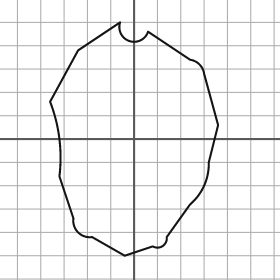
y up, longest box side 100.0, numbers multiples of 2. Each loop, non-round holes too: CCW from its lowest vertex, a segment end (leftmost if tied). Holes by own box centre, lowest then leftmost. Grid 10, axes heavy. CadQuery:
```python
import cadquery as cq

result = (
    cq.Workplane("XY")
    .moveTo(-4.0, -50.0)
    .lineTo(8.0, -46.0)
    .threePointArc((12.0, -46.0), (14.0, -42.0))
    .lineTo(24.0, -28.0)
    .threePointArc((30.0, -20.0), (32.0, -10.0))
    .lineTo(36.0, 6.0)
    .lineTo(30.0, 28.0)
    .threePointArc((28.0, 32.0), (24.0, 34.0))
    .lineTo(6.0, 46.0)
    .threePointArc((-2.0, 42.0), (-6.0, 50.0))
    .lineTo(-24.0, 38.0)
    .lineTo(-36.0, 16.0)
    .threePointArc((-32.0, 0.0), (-32.0, -16.0))
    .lineTo(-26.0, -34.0)
    .threePointArc((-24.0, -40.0), (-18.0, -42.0))
    .close()
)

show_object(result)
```